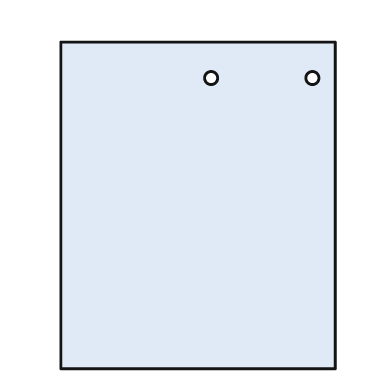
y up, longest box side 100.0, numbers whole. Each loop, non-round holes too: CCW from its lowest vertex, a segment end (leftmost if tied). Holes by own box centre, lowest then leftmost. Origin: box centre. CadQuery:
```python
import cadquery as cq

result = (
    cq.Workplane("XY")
    .moveTo(-42.0, -50.0)
    .lineTo(42.0, -50.0)
    .lineTo(42.0, 50.0)
    .lineTo(-42.0, 50.0)
    .close()
    .moveTo(4.0, 39.0)
    .circle(2.0)
    .moveTo(35.0, 39.0)
    .circle(2.0)
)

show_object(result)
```